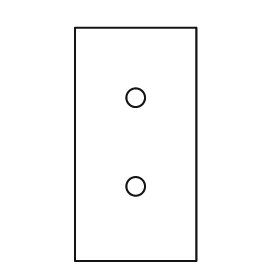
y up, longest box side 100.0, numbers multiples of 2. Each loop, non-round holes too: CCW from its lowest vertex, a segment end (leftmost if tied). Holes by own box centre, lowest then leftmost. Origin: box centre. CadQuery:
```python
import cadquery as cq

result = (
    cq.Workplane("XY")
    .moveTo(-26.0, -50.0)
    .lineTo(26.0, -50.0)
    .lineTo(26.0, 50.0)
    .lineTo(-26.0, 50.0)
    .close()
    .moveTo(0.0, -18.0)
    .circle(4.0)
    .moveTo(0.0, 20.0)
    .circle(4.0)
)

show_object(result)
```